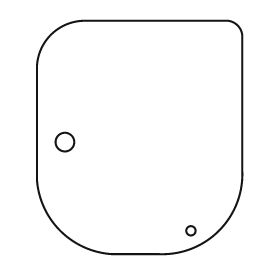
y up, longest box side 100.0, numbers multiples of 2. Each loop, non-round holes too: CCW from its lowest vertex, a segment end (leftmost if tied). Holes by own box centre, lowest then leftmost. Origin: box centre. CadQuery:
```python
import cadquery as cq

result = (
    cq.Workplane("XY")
    .moveTo(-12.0, -50.0)
    .lineTo(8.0, -50.0)
    .threePointArc((34.0, -40.0), (44.0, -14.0))
    .lineTo(44.0, 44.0)
    .threePointArc((42.0, 48.0), (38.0, 50.0))
    .lineTo(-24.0, 50.0)
    .threePointArc((-38.0, 44.0), (-44.0, 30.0))
    .lineTo(-44.0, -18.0)
    .threePointArc((-34.0, -40.0), (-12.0, -50.0))
    .close()
    .moveTo(22.0, -40.0)
    .circle(2.0)
    .moveTo(-32.0, -2.0)
    .circle(4.0)
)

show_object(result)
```